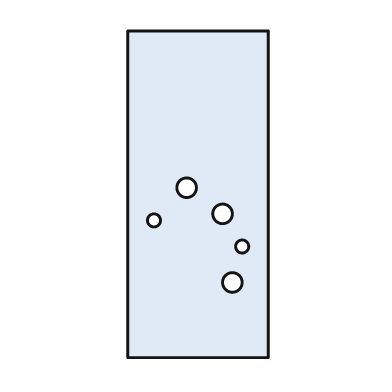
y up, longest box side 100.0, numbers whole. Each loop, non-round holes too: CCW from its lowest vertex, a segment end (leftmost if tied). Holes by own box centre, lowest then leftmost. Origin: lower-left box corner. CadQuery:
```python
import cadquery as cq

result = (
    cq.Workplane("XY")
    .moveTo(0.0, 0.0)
    .lineTo(43.0, 0.0)
    .lineTo(43.0, 100.0)
    .lineTo(0.0, 100.0)
    .close()
    .moveTo(32.0, 23.0)
    .circle(3.0)
    .moveTo(35.0, 34.0)
    .circle(2.0)
    .moveTo(8.0, 42.0)
    .circle(2.0)
    .moveTo(29.0, 44.0)
    .circle(3.0)
    .moveTo(18.0, 52.0)
    .circle(3.0)
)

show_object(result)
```